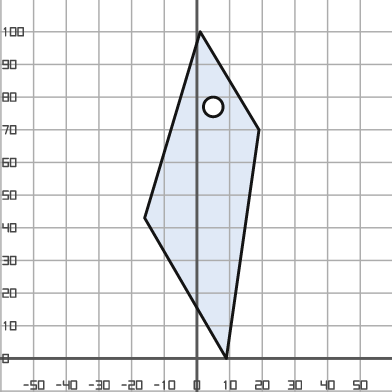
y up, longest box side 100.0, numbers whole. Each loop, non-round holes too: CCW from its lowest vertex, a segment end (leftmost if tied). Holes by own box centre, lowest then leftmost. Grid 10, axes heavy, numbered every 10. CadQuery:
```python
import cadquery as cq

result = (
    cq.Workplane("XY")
    .moveTo(9.0, 0.0)
    .lineTo(19.0, 70.0)
    .lineTo(1.0, 100.0)
    .lineTo(-16.0, 43.0)
    .close()
    .moveTo(5.0, 77.0)
    .circle(3.0)
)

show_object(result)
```